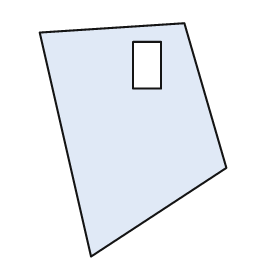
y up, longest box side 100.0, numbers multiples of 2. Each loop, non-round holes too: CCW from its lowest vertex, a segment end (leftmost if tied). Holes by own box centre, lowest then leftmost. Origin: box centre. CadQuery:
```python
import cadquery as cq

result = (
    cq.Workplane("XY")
    .moveTo(-18.0, -50.0)
    .lineTo(40.0, -12.0)
    .lineTo(22.0, 50.0)
    .lineTo(-40.0, 46.0)
    .close()
    .moveTo(0.0, 22.0)
    .lineTo(12.0, 22.0)
    .lineTo(12.0, 42.0)
    .lineTo(0.0, 42.0)
    .close()
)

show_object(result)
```